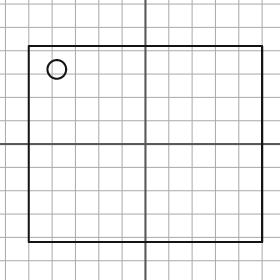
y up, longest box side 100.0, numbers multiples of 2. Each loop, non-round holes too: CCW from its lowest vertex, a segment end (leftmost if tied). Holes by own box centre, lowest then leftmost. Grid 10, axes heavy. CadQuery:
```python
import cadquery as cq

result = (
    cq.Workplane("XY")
    .moveTo(-50.0, -42.0)
    .lineTo(50.0, -42.0)
    .lineTo(50.0, 42.0)
    .lineTo(-50.0, 42.0)
    .close()
    .moveTo(-38.0, 32.0)
    .circle(4.0)
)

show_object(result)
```